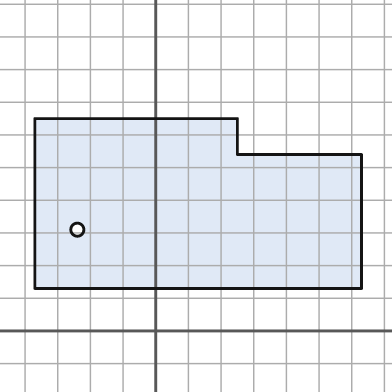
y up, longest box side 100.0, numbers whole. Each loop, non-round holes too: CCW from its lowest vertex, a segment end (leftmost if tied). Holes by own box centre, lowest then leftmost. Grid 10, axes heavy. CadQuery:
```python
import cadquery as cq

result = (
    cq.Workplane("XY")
    .moveTo(-37.0, 13.0)
    .lineTo(63.0, 13.0)
    .lineTo(63.0, 54.0)
    .lineTo(25.0, 54.0)
    .lineTo(25.0, 65.0)
    .lineTo(-37.0, 65.0)
    .close()
    .moveTo(-24.0, 31.0)
    .circle(2.0)
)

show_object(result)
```